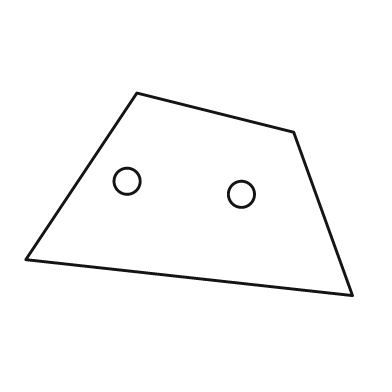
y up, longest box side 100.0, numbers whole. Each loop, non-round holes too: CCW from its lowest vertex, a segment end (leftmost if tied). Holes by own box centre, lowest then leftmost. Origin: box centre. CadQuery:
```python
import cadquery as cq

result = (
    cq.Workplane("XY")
    .moveTo(50.0, -31.0)
    .lineTo(32.0, 19.0)
    .lineTo(-16.0, 31.0)
    .lineTo(-50.0, -20.0)
    .close()
    .moveTo(16.0, 0.0)
    .circle(4.0)
    .moveTo(-19.0, 4.0)
    .circle(4.0)
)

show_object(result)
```